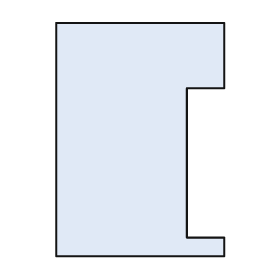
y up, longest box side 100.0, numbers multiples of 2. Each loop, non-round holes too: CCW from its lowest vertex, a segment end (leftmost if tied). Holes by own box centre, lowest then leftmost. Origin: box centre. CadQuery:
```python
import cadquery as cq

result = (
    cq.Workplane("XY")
    .moveTo(-36.0, -50.0)
    .lineTo(36.0, -50.0)
    .lineTo(36.0, -42.0)
    .lineTo(20.0, -42.0)
    .lineTo(20.0, 22.0)
    .lineTo(36.0, 22.0)
    .lineTo(36.0, 50.0)
    .lineTo(-36.0, 50.0)
    .close()
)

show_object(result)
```